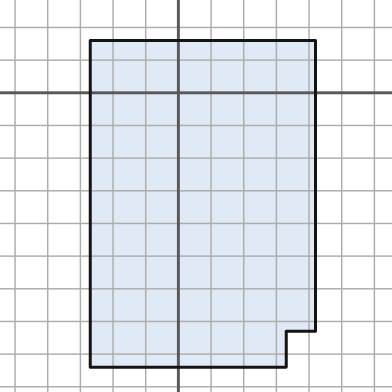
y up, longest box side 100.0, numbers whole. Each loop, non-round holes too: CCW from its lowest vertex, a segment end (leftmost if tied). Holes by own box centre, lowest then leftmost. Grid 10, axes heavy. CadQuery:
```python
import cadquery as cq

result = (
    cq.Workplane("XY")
    .moveTo(-27.0, -84.0)
    .lineTo(33.0, -84.0)
    .lineTo(33.0, -73.0)
    .lineTo(42.0, -73.0)
    .lineTo(42.0, 16.0)
    .lineTo(-27.0, 16.0)
    .close()
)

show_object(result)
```